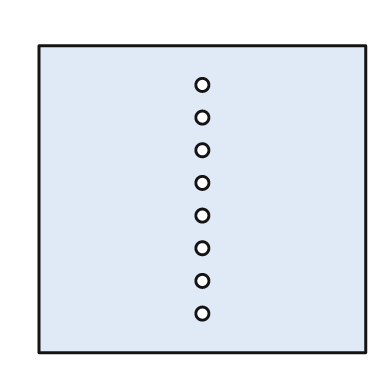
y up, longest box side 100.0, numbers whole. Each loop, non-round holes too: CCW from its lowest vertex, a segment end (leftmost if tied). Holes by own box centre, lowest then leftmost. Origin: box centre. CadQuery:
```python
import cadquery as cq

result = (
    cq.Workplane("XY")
    .moveTo(-50.0, -47.0)
    .lineTo(50.0, -47.0)
    .lineTo(50.0, 47.0)
    .lineTo(-50.0, 47.0)
    .close()
    .moveTo(0.0, -35.0)
    .circle(2.0)
    .moveTo(0.0, -25.0)
    .circle(2.0)
    .moveTo(0.0, -15.0)
    .circle(2.0)
    .moveTo(0.0, -5.0)
    .circle(2.0)
    .moveTo(0.0, 5.0)
    .circle(2.0)
    .moveTo(0.0, 15.0)
    .circle(2.0)
    .moveTo(0.0, 25.0)
    .circle(2.0)
    .moveTo(0.0, 35.0)
    .circle(2.0)
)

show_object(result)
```